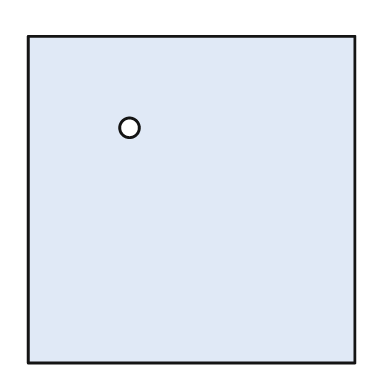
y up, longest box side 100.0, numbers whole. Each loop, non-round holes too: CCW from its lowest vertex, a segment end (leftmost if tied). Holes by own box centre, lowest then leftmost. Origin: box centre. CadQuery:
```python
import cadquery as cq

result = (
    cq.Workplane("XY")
    .moveTo(-50.0, -50.0)
    .lineTo(50.0, -50.0)
    .lineTo(50.0, 50.0)
    .lineTo(-50.0, 50.0)
    .close()
    .moveTo(-19.0, 22.0)
    .circle(3.0)
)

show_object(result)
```